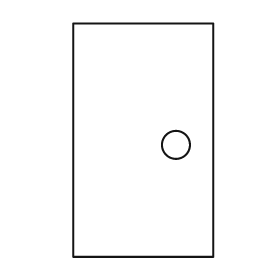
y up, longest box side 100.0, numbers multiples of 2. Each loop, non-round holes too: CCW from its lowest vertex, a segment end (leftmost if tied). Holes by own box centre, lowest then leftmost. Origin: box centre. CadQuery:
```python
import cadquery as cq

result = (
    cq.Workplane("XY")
    .moveTo(-30.0, -50.0)
    .lineTo(30.0, -50.0)
    .lineTo(30.0, 50.0)
    .lineTo(-30.0, 50.0)
    .close()
    .moveTo(14.0, -2.0)
    .circle(6.0)
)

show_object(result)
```